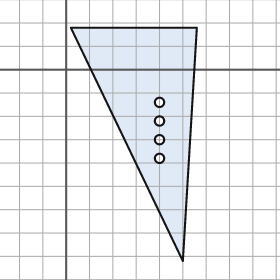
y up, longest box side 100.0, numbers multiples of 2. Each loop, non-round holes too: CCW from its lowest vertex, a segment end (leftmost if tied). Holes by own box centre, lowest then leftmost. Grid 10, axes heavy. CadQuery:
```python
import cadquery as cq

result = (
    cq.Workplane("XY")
    .moveTo(50.0, -82.0)
    .lineTo(56.0, 18.0)
    .lineTo(2.0, 18.0)
    .close()
    .moveTo(40.0, -38.0)
    .circle(2.0)
    .moveTo(40.0, -30.0)
    .circle(2.0)
    .moveTo(40.0, -22.0)
    .circle(2.0)
    .moveTo(40.0, -14.0)
    .circle(2.0)
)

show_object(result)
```